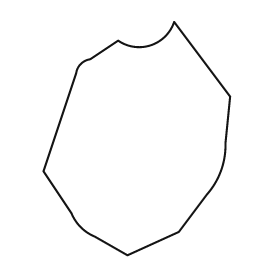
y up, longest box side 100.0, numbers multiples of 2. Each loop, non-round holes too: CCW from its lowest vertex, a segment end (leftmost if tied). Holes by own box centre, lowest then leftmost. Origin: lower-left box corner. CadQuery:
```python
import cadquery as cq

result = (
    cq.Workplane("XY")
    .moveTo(36.0, 0.0)
    .lineTo(58.0, 10.0)
    .lineTo(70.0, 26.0)
    .threePointArc((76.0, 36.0), (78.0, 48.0))
    .lineTo(80.0, 68.0)
    .lineTo(56.0, 100.0)
    .threePointArc((46.0, 90.0), (32.0, 92.0))
    .lineTo(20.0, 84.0)
    .threePointArc((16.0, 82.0), (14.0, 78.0))
    .lineTo(0.0, 36.0)
    .lineTo(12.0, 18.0)
    .threePointArc((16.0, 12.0), (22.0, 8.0))
    .close()
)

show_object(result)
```